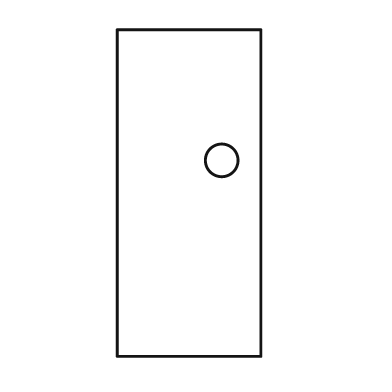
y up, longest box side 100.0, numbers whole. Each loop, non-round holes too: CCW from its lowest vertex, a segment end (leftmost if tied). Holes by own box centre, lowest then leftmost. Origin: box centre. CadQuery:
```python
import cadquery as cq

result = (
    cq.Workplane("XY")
    .moveTo(-22.0, -50.0)
    .lineTo(22.0, -50.0)
    .lineTo(22.0, 50.0)
    .lineTo(-22.0, 50.0)
    .close()
    .moveTo(10.0, 10.0)
    .circle(5.0)
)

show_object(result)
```